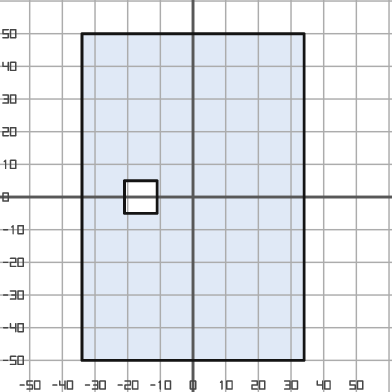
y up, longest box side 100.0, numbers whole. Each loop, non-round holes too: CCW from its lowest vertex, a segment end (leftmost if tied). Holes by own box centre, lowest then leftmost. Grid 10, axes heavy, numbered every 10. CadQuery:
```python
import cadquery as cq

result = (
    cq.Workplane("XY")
    .moveTo(-34.0, -50.0)
    .lineTo(34.0, -50.0)
    .lineTo(34.0, 50.0)
    .lineTo(-34.0, 50.0)
    .close()
    .moveTo(-21.0, -5.0)
    .lineTo(-11.0, -5.0)
    .lineTo(-11.0, 5.0)
    .lineTo(-21.0, 5.0)
    .close()
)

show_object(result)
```